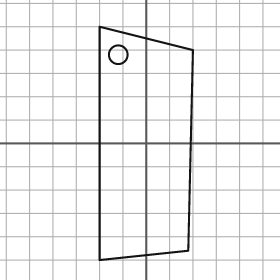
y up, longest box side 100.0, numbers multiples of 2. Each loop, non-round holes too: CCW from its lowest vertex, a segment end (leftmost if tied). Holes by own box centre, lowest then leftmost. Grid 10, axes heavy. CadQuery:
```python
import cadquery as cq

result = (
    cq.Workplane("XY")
    .moveTo(-20.0, -50.0)
    .lineTo(18.0, -46.0)
    .lineTo(20.0, 40.0)
    .lineTo(-20.0, 50.0)
    .close()
    .moveTo(-12.0, 38.0)
    .circle(4.0)
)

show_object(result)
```